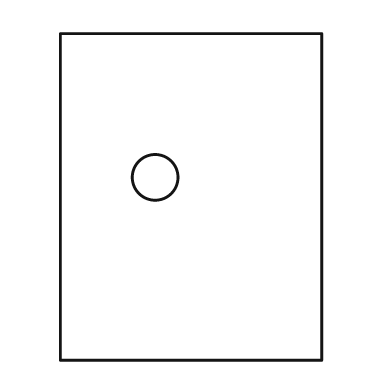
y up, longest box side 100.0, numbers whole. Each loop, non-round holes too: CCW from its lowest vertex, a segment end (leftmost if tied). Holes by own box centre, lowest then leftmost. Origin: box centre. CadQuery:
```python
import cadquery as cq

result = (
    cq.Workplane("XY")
    .moveTo(-40.0, -50.0)
    .lineTo(40.0, -50.0)
    .lineTo(40.0, 50.0)
    .lineTo(-40.0, 50.0)
    .close()
    .moveTo(-11.0, 6.0)
    .circle(7.0)
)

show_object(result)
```